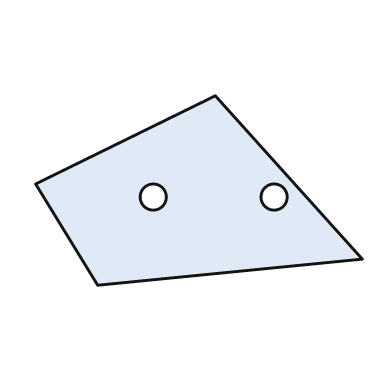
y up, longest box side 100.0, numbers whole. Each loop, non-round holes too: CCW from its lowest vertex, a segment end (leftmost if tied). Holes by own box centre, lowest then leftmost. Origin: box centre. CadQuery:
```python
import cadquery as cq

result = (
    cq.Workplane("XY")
    .moveTo(-31.0, -29.0)
    .lineTo(50.0, -21.0)
    .lineTo(5.0, 29.0)
    .lineTo(-50.0, 2.0)
    .close()
    .moveTo(-14.0, -2.0)
    .circle(4.0)
    .moveTo(23.0, -2.0)
    .circle(4.0)
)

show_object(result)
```